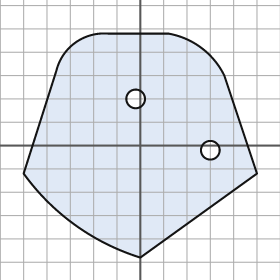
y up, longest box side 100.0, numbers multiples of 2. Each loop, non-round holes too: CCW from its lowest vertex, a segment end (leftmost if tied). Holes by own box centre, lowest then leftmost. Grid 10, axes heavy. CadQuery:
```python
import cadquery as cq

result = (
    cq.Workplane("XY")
    .moveTo(0.0, -48.0)
    .lineTo(50.0, -12.0)
    .lineTo(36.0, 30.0)
    .threePointArc((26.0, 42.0), (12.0, 48.0))
    .lineTo(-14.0, 48.0)
    .threePointArc((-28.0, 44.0), (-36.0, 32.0))
    .lineTo(-50.0, -12.0)
    .threePointArc((-28.0, -34.0), (0.0, -48.0))
    .close()
    .moveTo(30.0, -2.0)
    .circle(4.0)
    .moveTo(-2.0, 20.0)
    .circle(4.0)
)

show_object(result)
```